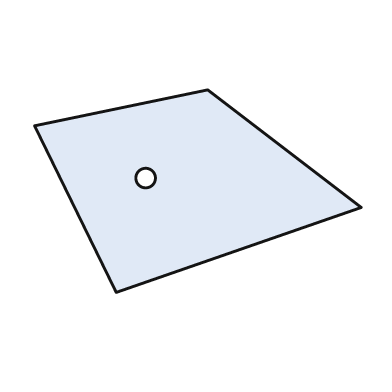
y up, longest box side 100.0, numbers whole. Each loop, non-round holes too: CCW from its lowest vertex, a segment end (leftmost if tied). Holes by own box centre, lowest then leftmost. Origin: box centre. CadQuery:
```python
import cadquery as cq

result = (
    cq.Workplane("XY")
    .moveTo(-25.0, -31.0)
    .lineTo(50.0, -5.0)
    .lineTo(3.0, 31.0)
    .lineTo(-50.0, 20.0)
    .close()
    .moveTo(-16.0, 4.0)
    .circle(3.0)
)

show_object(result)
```